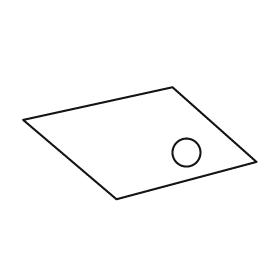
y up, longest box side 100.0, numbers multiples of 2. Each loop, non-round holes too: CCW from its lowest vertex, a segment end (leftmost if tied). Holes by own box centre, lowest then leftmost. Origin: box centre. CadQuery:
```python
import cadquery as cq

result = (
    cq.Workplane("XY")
    .moveTo(-10.0, -24.0)
    .lineTo(50.0, -8.0)
    .lineTo(14.0, 24.0)
    .lineTo(-50.0, 10.0)
    .close()
    .moveTo(20.0, -4.0)
    .circle(6.0)
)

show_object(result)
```